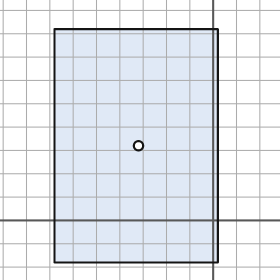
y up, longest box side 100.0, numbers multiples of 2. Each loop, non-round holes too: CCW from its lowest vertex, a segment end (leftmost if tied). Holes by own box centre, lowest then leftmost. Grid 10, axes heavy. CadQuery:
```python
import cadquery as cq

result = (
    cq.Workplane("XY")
    .moveTo(-68.0, -18.0)
    .lineTo(2.0, -18.0)
    .lineTo(2.0, 82.0)
    .lineTo(-68.0, 82.0)
    .close()
    .moveTo(-32.0, 32.0)
    .circle(2.0)
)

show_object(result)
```